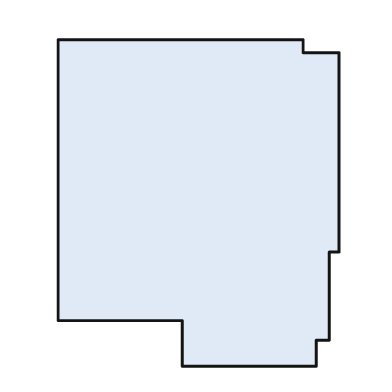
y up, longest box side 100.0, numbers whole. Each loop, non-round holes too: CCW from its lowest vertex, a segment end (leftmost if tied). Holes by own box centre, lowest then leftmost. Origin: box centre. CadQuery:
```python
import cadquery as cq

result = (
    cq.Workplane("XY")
    .moveTo(-5.0, -50.0)
    .lineTo(36.0, -50.0)
    .lineTo(36.0, -42.0)
    .lineTo(40.0, -42.0)
    .lineTo(40.0, -15.0)
    .lineTo(43.0, -15.0)
    .lineTo(43.0, 46.0)
    .lineTo(32.0, 46.0)
    .lineTo(32.0, 50.0)
    .lineTo(-43.0, 50.0)
    .lineTo(-43.0, -36.0)
    .lineTo(-5.0, -36.0)
    .close()
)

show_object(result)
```